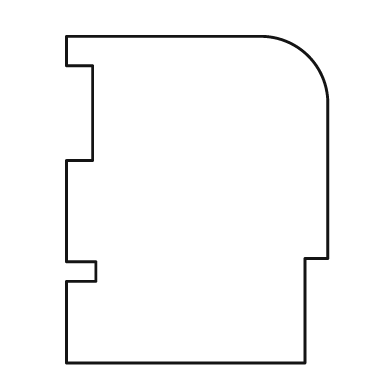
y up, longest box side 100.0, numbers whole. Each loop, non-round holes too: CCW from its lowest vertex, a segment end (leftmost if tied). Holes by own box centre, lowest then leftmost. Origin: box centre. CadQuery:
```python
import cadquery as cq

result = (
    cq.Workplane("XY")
    .moveTo(-40.0, -50.0)
    .lineTo(33.0, -50.0)
    .lineTo(33.0, -18.0)
    .lineTo(40.0, -18.0)
    .lineTo(40.0, 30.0)
    .threePointArc((34.0, 44.0), (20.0, 50.0))
    .lineTo(-40.0, 50.0)
    .lineTo(-40.0, 41.0)
    .lineTo(-32.0, 41.0)
    .lineTo(-32.0, 12.0)
    .lineTo(-40.0, 12.0)
    .lineTo(-40.0, -19.0)
    .lineTo(-31.0, -19.0)
    .lineTo(-31.0, -25.0)
    .lineTo(-40.0, -25.0)
    .close()
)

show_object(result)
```